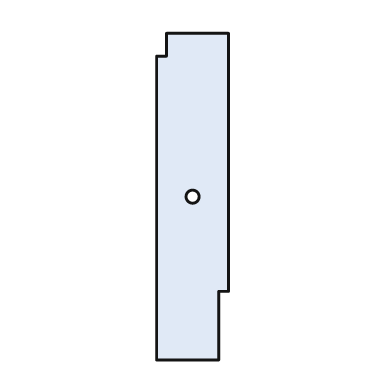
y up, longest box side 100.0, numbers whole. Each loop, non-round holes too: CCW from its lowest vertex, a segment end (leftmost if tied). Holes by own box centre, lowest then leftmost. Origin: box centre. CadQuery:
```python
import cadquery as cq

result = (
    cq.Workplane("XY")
    .moveTo(-11.0, -50.0)
    .lineTo(8.0, -50.0)
    .lineTo(8.0, -29.0)
    .lineTo(11.0, -29.0)
    .lineTo(11.0, 50.0)
    .lineTo(-8.0, 50.0)
    .lineTo(-8.0, 43.0)
    .lineTo(-11.0, 43.0)
    .close()
    .moveTo(0.0, 0.0)
    .circle(2.0)
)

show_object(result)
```